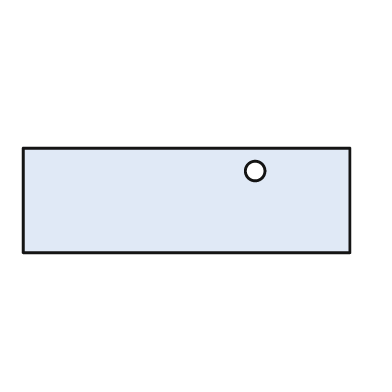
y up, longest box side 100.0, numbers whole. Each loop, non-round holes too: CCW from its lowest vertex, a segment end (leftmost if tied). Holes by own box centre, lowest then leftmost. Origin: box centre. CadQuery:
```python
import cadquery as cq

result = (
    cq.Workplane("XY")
    .moveTo(-50.0, -16.0)
    .lineTo(50.0, -16.0)
    .lineTo(50.0, 16.0)
    .lineTo(-50.0, 16.0)
    .close()
    .moveTo(21.0, 9.0)
    .circle(3.0)
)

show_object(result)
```